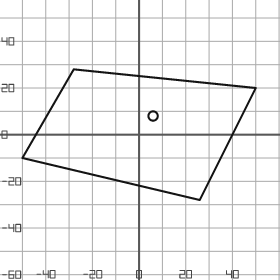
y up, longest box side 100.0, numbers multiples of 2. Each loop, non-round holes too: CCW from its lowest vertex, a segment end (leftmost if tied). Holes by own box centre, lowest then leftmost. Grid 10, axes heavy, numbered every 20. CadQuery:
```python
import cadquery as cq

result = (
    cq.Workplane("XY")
    .moveTo(26.0, -28.0)
    .lineTo(50.0, 20.0)
    .lineTo(-28.0, 28.0)
    .lineTo(-50.0, -10.0)
    .close()
    .moveTo(6.0, 8.0)
    .circle(2.0)
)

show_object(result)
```